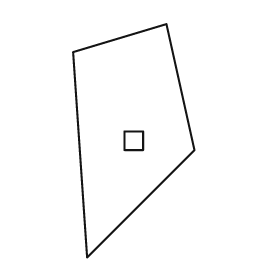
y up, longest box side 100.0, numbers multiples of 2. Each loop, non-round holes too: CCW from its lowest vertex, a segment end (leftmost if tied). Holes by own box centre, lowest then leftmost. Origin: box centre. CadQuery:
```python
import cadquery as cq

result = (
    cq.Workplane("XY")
    .moveTo(-20.0, -50.0)
    .lineTo(26.0, -4.0)
    .lineTo(14.0, 50.0)
    .lineTo(-26.0, 38.0)
    .close()
    .moveTo(-4.0, -4.0)
    .lineTo(4.0, -4.0)
    .lineTo(4.0, 4.0)
    .lineTo(-4.0, 4.0)
    .close()
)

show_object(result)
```